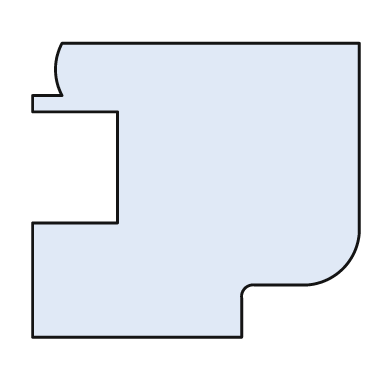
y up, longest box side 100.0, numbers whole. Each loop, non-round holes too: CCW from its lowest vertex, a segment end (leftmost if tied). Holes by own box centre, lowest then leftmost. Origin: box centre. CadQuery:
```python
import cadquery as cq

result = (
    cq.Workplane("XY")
    .moveTo(-50.0, -45.0)
    .lineTo(14.0, -45.0)
    .lineTo(14.0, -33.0)
    .threePointArc((15.0, -30.0), (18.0, -29.0))
    .lineTo(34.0, -29.0)
    .threePointArc((45.0, -24.0), (50.0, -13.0))
    .lineTo(50.0, 45.0)
    .lineTo(-41.0, 45.0)
    .threePointArc((-43.0, 37.0), (-41.0, 29.0))
    .lineTo(-50.0, 29.0)
    .lineTo(-50.0, 24.0)
    .lineTo(-24.0, 24.0)
    .lineTo(-24.0, -10.0)
    .lineTo(-50.0, -10.0)
    .close()
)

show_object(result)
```